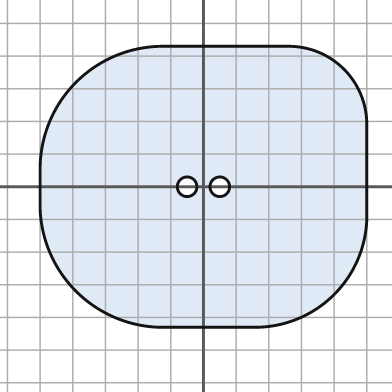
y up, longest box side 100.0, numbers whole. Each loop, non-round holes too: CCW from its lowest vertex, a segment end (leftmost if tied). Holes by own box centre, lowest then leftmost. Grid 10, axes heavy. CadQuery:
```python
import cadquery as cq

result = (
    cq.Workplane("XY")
    .moveTo(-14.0, -43.0)
    .lineTo(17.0, -43.0)
    .threePointArc((40.0, -33.0), (50.0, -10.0))
    .lineTo(50.0, 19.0)
    .threePointArc((43.0, 36.0), (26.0, 43.0))
    .lineTo(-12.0, 43.0)
    .threePointArc((-39.0, 32.0), (-50.0, 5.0))
    .lineTo(-50.0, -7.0)
    .threePointArc((-39.0, -32.0), (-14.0, -43.0))
    .close()
    .moveTo(-5.0, 0.0)
    .circle(3.0)
    .moveTo(5.0, 0.0)
    .circle(3.0)
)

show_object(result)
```